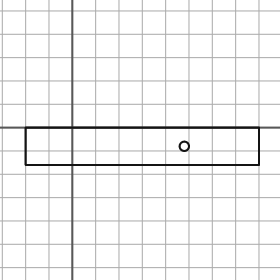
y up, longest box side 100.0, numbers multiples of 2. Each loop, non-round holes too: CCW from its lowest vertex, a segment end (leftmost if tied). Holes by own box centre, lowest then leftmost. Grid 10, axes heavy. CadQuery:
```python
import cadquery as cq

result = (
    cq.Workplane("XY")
    .moveTo(-20.0, -16.0)
    .lineTo(80.0, -16.0)
    .lineTo(80.0, 0.0)
    .lineTo(-20.0, 0.0)
    .close()
    .moveTo(48.0, -8.0)
    .circle(2.0)
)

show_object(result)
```